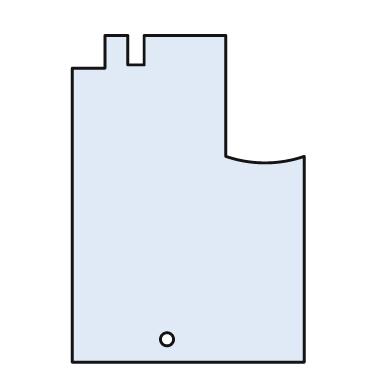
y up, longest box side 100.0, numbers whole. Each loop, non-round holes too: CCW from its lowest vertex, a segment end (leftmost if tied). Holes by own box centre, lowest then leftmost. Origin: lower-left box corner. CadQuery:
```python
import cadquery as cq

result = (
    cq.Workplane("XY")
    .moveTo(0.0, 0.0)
    .lineTo(71.0, 0.0)
    .lineTo(71.0, 63.0)
    .threePointArc((59.0, 61.0), (47.0, 63.0))
    .lineTo(47.0, 100.0)
    .lineTo(22.0, 100.0)
    .lineTo(22.0, 91.0)
    .lineTo(17.0, 91.0)
    .lineTo(17.0, 100.0)
    .lineTo(10.0, 100.0)
    .lineTo(10.0, 90.0)
    .lineTo(0.0, 90.0)
    .close()
    .moveTo(29.0, 7.0)
    .circle(2.0)
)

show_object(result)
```